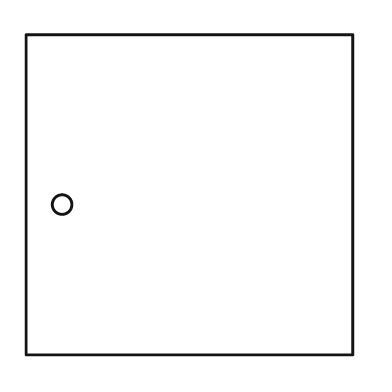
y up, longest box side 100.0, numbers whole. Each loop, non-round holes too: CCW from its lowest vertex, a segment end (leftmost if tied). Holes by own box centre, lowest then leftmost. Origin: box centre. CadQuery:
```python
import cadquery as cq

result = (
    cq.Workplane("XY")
    .moveTo(-50.0, -49.0)
    .lineTo(50.0, -49.0)
    .lineTo(50.0, 49.0)
    .lineTo(-50.0, 49.0)
    .close()
    .moveTo(-39.0, -3.0)
    .circle(3.0)
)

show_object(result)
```